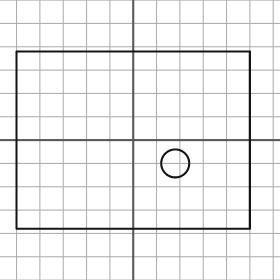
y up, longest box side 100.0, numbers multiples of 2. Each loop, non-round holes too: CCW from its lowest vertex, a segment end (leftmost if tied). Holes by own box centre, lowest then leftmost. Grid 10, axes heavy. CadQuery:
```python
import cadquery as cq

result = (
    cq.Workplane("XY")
    .moveTo(-50.0, -38.0)
    .lineTo(50.0, -38.0)
    .lineTo(50.0, 38.0)
    .lineTo(-50.0, 38.0)
    .close()
    .moveTo(18.0, -10.0)
    .circle(6.0)
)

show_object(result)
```